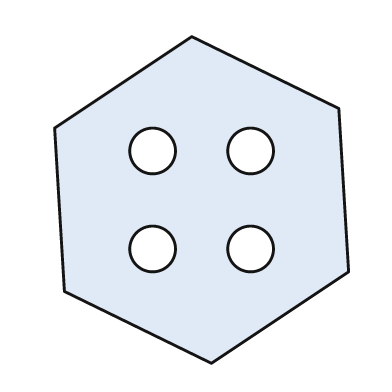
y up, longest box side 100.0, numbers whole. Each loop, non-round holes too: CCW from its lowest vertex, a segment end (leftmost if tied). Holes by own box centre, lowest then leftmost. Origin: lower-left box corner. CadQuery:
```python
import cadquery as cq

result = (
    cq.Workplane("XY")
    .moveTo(48.0, 0.0)
    .lineTo(90.0, 28.0)
    .lineTo(87.0, 78.0)
    .lineTo(42.0, 100.0)
    .lineTo(0.0, 72.0)
    .lineTo(3.0, 22.0)
    .close()
    .moveTo(30.0, 35.0)
    .circle(7.0)
    .moveTo(60.0, 35.0)
    .circle(7.0)
    .moveTo(30.0, 65.0)
    .circle(7.0)
    .moveTo(60.0, 65.0)
    .circle(7.0)
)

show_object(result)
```